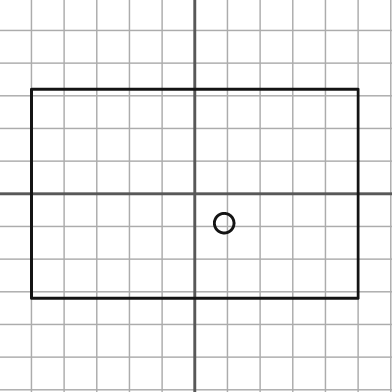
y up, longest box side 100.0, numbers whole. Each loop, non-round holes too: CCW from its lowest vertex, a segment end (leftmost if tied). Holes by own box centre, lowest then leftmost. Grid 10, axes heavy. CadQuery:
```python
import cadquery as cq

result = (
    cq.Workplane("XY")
    .moveTo(-50.0, -32.0)
    .lineTo(50.0, -32.0)
    .lineTo(50.0, 32.0)
    .lineTo(-50.0, 32.0)
    .close()
    .moveTo(9.0, -9.0)
    .circle(3.0)
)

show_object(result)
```